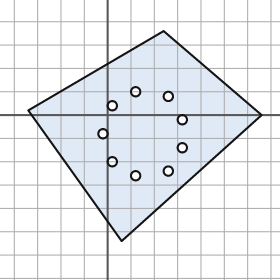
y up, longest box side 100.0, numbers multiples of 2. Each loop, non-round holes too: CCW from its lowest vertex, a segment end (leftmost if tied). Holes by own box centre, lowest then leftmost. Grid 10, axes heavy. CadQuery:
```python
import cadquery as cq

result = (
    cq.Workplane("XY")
    .moveTo(6.0, -54.0)
    .lineTo(66.0, 0.0)
    .lineTo(24.0, 36.0)
    .lineTo(-34.0, 2.0)
    .close()
    .moveTo(12.0, -26.0)
    .circle(2.0)
    .moveTo(26.0, -24.0)
    .circle(2.0)
    .moveTo(2.0, -20.0)
    .circle(2.0)
    .moveTo(32.0, -14.0)
    .circle(2.0)
    .moveTo(-2.0, -8.0)
    .circle(2.0)
    .moveTo(32.0, -2.0)
    .circle(2.0)
    .moveTo(2.0, 4.0)
    .circle(2.0)
    .moveTo(26.0, 8.0)
    .circle(2.0)
    .moveTo(12.0, 10.0)
    .circle(2.0)
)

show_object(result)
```